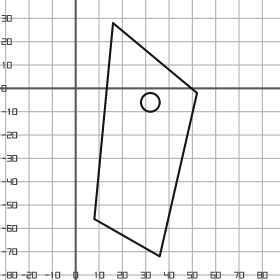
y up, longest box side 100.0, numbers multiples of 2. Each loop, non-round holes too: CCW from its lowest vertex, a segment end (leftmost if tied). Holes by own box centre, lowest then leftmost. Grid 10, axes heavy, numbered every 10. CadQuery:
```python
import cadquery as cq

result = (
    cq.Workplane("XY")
    .moveTo(36.0, -72.0)
    .lineTo(52.0, -2.0)
    .lineTo(16.0, 28.0)
    .lineTo(8.0, -56.0)
    .close()
    .moveTo(32.0, -6.0)
    .circle(4.0)
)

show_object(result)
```